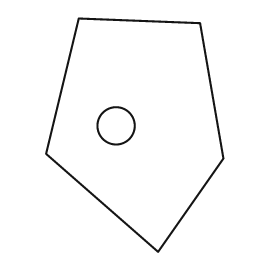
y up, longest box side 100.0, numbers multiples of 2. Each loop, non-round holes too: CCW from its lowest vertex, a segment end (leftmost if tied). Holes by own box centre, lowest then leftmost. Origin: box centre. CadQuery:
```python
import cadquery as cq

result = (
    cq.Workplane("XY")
    .moveTo(10.0, -50.0)
    .lineTo(38.0, -10.0)
    .lineTo(28.0, 48.0)
    .lineTo(-24.0, 50.0)
    .lineTo(-38.0, -8.0)
    .close()
    .moveTo(-8.0, 4.0)
    .circle(8.0)
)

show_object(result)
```